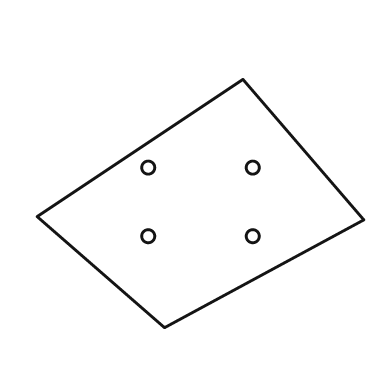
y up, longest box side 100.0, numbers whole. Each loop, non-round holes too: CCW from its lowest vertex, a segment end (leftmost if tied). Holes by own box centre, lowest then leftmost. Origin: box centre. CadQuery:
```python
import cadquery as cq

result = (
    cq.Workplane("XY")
    .moveTo(-11.0, -38.0)
    .lineTo(50.0, -5.0)
    .lineTo(13.0, 38.0)
    .lineTo(-50.0, -4.0)
    .close()
    .moveTo(-16.0, -10.0)
    .circle(2.0)
    .moveTo(16.0, -10.0)
    .circle(2.0)
    .moveTo(-16.0, 11.0)
    .circle(2.0)
    .moveTo(16.0, 11.0)
    .circle(2.0)
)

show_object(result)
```